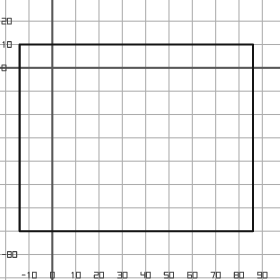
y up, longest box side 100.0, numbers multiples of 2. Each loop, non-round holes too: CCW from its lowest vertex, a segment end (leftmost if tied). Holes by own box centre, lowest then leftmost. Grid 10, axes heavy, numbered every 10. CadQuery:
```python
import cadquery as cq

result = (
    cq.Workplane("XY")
    .moveTo(-14.0, -70.0)
    .lineTo(86.0, -70.0)
    .lineTo(86.0, 10.0)
    .lineTo(-14.0, 10.0)
    .close()
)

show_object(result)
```